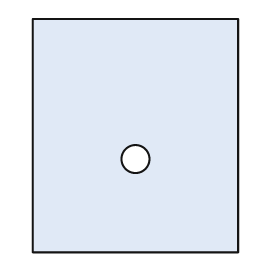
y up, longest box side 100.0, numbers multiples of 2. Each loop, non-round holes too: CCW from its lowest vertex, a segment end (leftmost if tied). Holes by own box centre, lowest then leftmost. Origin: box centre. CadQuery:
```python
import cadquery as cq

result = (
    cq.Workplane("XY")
    .moveTo(-44.0, -50.0)
    .lineTo(44.0, -50.0)
    .lineTo(44.0, 50.0)
    .lineTo(-44.0, 50.0)
    .close()
    .moveTo(0.0, -10.0)
    .circle(6.0)
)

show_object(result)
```